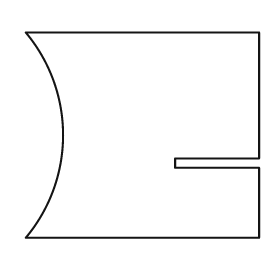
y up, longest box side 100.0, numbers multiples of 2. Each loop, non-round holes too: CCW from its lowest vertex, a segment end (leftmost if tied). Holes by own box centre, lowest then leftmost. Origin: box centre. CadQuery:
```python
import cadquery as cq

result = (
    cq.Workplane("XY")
    .moveTo(-50.0, -44.0)
    .lineTo(50.0, -44.0)
    .lineTo(50.0, -14.0)
    .lineTo(14.0, -14.0)
    .lineTo(14.0, -10.0)
    .lineTo(50.0, -10.0)
    .lineTo(50.0, 44.0)
    .lineTo(-50.0, 44.0)
    .threePointArc((-34.0, 0.0), (-50.0, -44.0))
    .close()
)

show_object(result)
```